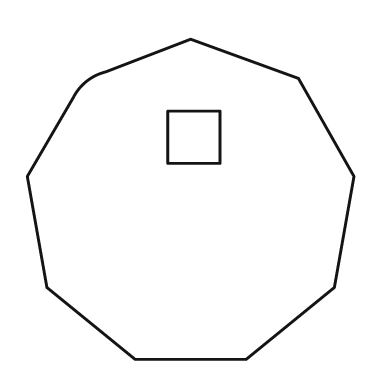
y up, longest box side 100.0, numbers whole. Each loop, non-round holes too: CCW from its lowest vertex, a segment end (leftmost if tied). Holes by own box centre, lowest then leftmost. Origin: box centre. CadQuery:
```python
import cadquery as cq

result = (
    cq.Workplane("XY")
    .moveTo(-17.0, -49.0)
    .lineTo(17.0, -49.0)
    .lineTo(44.0, -27.0)
    .lineTo(50.0, 7.0)
    .lineTo(33.0, 37.0)
    .lineTo(0.0, 49.0)
    .lineTo(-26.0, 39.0)
    .threePointArc((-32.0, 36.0), (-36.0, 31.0))
    .lineTo(-50.0, 7.0)
    .lineTo(-44.0, -27.0)
    .close()
    .moveTo(-7.0, 11.0)
    .lineTo(9.0, 11.0)
    .lineTo(9.0, 27.0)
    .lineTo(-7.0, 27.0)
    .close()
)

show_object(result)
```